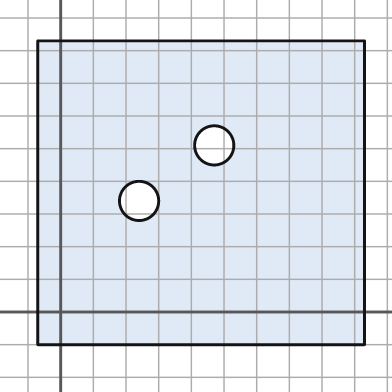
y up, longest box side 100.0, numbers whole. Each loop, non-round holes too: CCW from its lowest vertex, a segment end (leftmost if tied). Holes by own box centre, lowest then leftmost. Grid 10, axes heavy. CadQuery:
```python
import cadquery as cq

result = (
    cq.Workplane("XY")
    .moveTo(-7.0, -10.0)
    .lineTo(93.0, -10.0)
    .lineTo(93.0, 83.0)
    .lineTo(-7.0, 83.0)
    .close()
    .moveTo(24.0, 34.0)
    .circle(6.0)
    .moveTo(47.0, 51.0)
    .circle(6.0)
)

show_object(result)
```